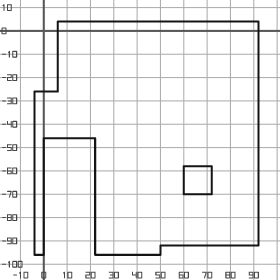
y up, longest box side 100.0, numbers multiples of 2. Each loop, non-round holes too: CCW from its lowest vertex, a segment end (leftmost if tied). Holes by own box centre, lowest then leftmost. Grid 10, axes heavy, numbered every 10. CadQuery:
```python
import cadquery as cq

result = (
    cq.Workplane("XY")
    .moveTo(-4.0, -96.0)
    .lineTo(0.0, -96.0)
    .lineTo(0.0, -46.0)
    .lineTo(22.0, -46.0)
    .lineTo(22.0, -96.0)
    .lineTo(50.0, -96.0)
    .lineTo(50.0, -92.0)
    .lineTo(92.0, -92.0)
    .lineTo(92.0, 4.0)
    .lineTo(6.0, 4.0)
    .lineTo(6.0, -26.0)
    .lineTo(-4.0, -26.0)
    .close()
    .moveTo(60.0, -70.0)
    .lineTo(72.0, -70.0)
    .lineTo(72.0, -58.0)
    .lineTo(60.0, -58.0)
    .close()
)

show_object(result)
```